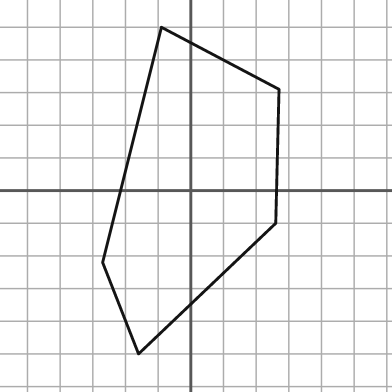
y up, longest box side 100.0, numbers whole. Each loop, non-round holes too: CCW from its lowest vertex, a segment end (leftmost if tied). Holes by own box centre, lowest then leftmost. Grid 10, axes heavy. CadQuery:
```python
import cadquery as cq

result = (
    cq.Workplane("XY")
    .moveTo(-16.0, -50.0)
    .lineTo(26.0, -10.0)
    .lineTo(27.0, 31.0)
    .lineTo(-9.0, 50.0)
    .lineTo(-27.0, -22.0)
    .close()
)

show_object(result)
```